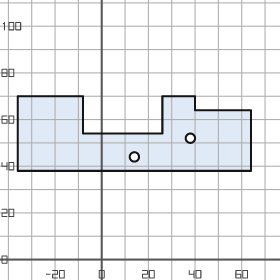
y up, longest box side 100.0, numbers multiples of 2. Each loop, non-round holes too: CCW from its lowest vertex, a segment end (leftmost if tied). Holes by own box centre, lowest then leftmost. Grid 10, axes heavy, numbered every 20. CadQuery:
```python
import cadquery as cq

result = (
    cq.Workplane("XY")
    .moveTo(-36.0, 38.0)
    .lineTo(64.0, 38.0)
    .lineTo(64.0, 64.0)
    .lineTo(40.0, 64.0)
    .lineTo(40.0, 70.0)
    .lineTo(26.0, 70.0)
    .lineTo(26.0, 54.0)
    .lineTo(-8.0, 54.0)
    .lineTo(-8.0, 70.0)
    .lineTo(-36.0, 70.0)
    .close()
    .moveTo(14.0, 44.0)
    .circle(2.0)
    .moveTo(38.0, 52.0)
    .circle(2.0)
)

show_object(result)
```